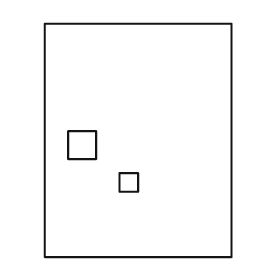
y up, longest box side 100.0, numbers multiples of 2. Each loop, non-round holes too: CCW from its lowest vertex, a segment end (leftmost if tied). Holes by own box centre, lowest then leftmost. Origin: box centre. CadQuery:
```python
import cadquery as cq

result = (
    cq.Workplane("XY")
    .moveTo(-40.0, -50.0)
    .lineTo(40.0, -50.0)
    .lineTo(40.0, 50.0)
    .lineTo(-40.0, 50.0)
    .close()
    .moveTo(-8.0, -22.0)
    .lineTo(0.0, -22.0)
    .lineTo(0.0, -14.0)
    .lineTo(-8.0, -14.0)
    .close()
    .moveTo(-30.0, -8.0)
    .lineTo(-18.0, -8.0)
    .lineTo(-18.0, 4.0)
    .lineTo(-30.0, 4.0)
    .close()
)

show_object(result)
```